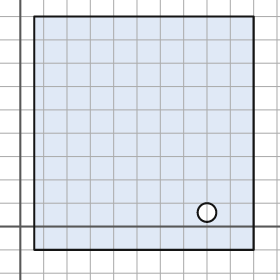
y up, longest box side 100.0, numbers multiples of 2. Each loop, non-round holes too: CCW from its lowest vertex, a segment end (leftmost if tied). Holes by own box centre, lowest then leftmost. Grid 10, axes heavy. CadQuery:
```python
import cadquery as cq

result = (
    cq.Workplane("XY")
    .moveTo(6.0, -10.0)
    .lineTo(100.0, -10.0)
    .lineTo(100.0, 90.0)
    .lineTo(6.0, 90.0)
    .close()
    .moveTo(80.0, 6.0)
    .circle(4.0)
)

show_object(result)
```